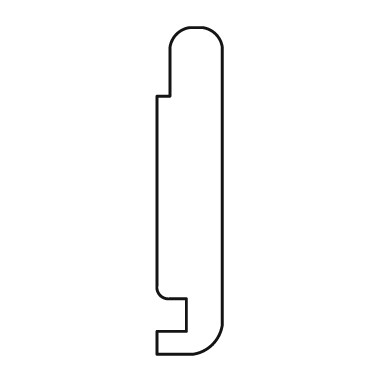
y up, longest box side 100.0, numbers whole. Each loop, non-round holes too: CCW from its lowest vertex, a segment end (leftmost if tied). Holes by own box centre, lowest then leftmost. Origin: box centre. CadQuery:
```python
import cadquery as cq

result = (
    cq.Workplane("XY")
    .moveTo(-10.0, -50.0)
    .lineTo(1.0, -50.0)
    .threePointArc((7.0, -47.0), (10.0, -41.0))
    .lineTo(10.0, 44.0)
    .threePointArc((8.0, 48.0), (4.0, 50.0))
    .lineTo(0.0, 50.0)
    .threePointArc((-4.0, 48.0), (-6.0, 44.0))
    .lineTo(-6.0, 29.0)
    .lineTo(-10.0, 29.0)
    .lineTo(-10.0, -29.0)
    .threePointArc((-9.0, -32.0), (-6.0, -33.0))
    .lineTo(-1.0, -33.0)
    .lineTo(-1.0, -43.0)
    .lineTo(-10.0, -43.0)
    .close()
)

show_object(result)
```